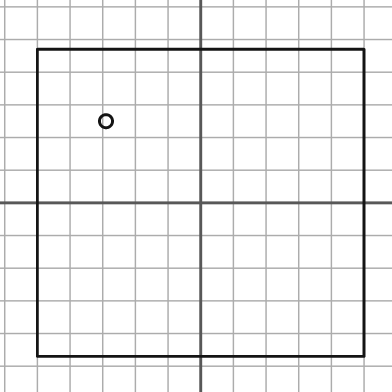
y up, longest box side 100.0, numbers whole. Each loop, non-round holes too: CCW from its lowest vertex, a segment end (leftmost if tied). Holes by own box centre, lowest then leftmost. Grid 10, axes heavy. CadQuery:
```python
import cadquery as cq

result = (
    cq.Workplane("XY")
    .moveTo(-50.0, -47.0)
    .lineTo(50.0, -47.0)
    .lineTo(50.0, 47.0)
    .lineTo(-50.0, 47.0)
    .close()
    .moveTo(-29.0, 25.0)
    .circle(2.0)
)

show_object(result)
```